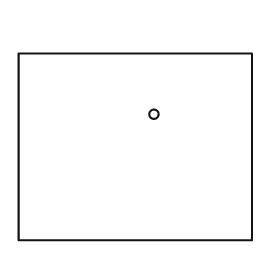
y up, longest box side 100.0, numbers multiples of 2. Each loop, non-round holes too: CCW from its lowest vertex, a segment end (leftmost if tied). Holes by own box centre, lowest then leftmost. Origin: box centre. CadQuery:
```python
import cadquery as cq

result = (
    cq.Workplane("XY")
    .moveTo(-50.0, -40.0)
    .lineTo(50.0, -40.0)
    .lineTo(50.0, 40.0)
    .lineTo(-50.0, 40.0)
    .close()
    .moveTo(8.0, 14.0)
    .circle(2.0)
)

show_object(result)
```